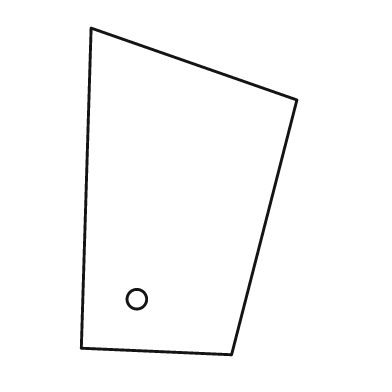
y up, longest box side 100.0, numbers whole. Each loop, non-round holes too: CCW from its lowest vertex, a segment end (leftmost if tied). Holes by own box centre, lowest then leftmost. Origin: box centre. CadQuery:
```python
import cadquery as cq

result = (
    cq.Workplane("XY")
    .moveTo(13.0, -50.0)
    .lineTo(33.0, 28.0)
    .lineTo(-30.0, 50.0)
    .lineTo(-33.0, -48.0)
    .close()
    .moveTo(-16.0, -33.0)
    .circle(3.0)
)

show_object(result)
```